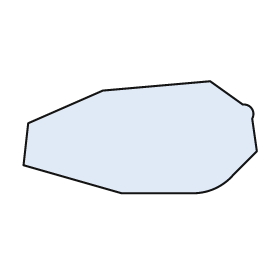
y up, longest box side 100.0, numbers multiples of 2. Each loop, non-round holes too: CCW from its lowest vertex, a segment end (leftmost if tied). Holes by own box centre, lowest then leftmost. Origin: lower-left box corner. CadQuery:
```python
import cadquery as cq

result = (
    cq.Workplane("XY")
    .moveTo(42.0, 0.0)
    .lineTo(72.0, 0.0)
    .threePointArc((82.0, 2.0), (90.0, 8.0))
    .lineTo(100.0, 18.0)
    .lineTo(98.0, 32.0)
    .threePointArc((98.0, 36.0), (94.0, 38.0))
    .lineTo(80.0, 48.0)
    .lineTo(34.0, 44.0)
    .lineTo(2.0, 30.0)
    .lineTo(0.0, 12.0)
    .close()
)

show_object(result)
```